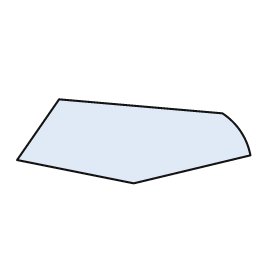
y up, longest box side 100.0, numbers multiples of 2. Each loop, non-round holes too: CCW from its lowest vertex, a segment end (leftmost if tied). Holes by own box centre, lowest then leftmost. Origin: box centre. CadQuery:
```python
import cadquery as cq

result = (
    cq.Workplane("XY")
    .moveTo(0.0, -18.0)
    .lineTo(50.0, -6.0)
    .threePointArc((46.0, 4.0), (38.0, 12.0))
    .lineTo(-32.0, 18.0)
    .lineTo(-50.0, -8.0)
    .close()
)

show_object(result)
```